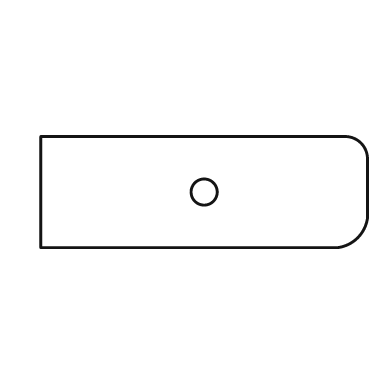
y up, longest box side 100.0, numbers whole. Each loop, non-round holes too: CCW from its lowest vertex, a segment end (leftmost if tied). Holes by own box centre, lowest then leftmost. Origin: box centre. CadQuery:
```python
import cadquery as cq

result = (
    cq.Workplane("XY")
    .moveTo(-50.0, -17.0)
    .lineTo(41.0, -17.0)
    .threePointArc((47.0, -14.0), (50.0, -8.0))
    .lineTo(50.0, 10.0)
    .threePointArc((48.0, 15.0), (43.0, 17.0))
    .lineTo(-50.0, 17.0)
    .close()
    .moveTo(0.0, 0.0)
    .circle(4.0)
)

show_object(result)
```